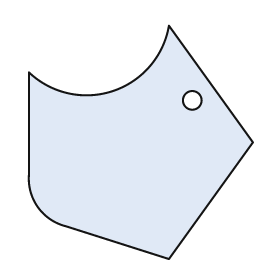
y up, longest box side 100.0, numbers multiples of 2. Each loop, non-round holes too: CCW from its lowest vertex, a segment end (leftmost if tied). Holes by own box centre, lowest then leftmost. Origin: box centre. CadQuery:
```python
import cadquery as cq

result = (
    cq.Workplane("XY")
    .moveTo(12.0, -50.0)
    .lineTo(48.0, 0.0)
    .lineTo(12.0, 50.0)
    .threePointArc((-12.0, 22.0), (-48.0, 30.0))
    .lineTo(-48.0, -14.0)
    .threePointArc((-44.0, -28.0), (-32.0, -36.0))
    .close()
    .moveTo(22.0, 18.0)
    .circle(4.0)
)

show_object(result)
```